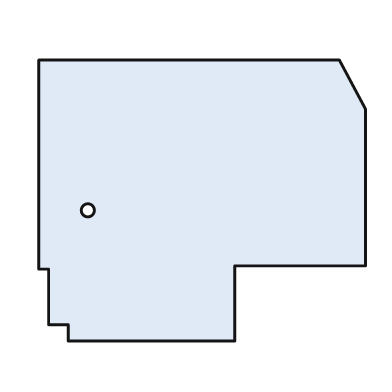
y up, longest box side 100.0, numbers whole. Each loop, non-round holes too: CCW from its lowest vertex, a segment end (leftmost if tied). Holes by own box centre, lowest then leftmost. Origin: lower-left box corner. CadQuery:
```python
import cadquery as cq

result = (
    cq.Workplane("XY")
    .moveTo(9.0, 0.0)
    .lineTo(60.0, 0.0)
    .lineTo(60.0, 23.0)
    .lineTo(100.0, 23.0)
    .lineTo(100.0, 71.0)
    .lineTo(92.0, 86.0)
    .lineTo(0.0, 86.0)
    .lineTo(0.0, 22.0)
    .lineTo(3.0, 22.0)
    .lineTo(3.0, 5.0)
    .lineTo(9.0, 5.0)
    .close()
    .moveTo(15.0, 40.0)
    .circle(2.0)
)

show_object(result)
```